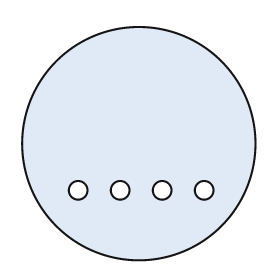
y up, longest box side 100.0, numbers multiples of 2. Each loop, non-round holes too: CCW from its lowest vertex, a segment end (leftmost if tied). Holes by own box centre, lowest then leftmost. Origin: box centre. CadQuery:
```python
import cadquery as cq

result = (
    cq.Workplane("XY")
    .moveTo(0.0, 0.0)
    .circle(50.0)
    .moveTo(-26.0, -20.0)
    .circle(4.0)
    .moveTo(-8.0, -20.0)
    .circle(4.0)
    .moveTo(10.0, -20.0)
    .circle(4.0)
    .moveTo(28.0, -20.0)
    .circle(4.0)
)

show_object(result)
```